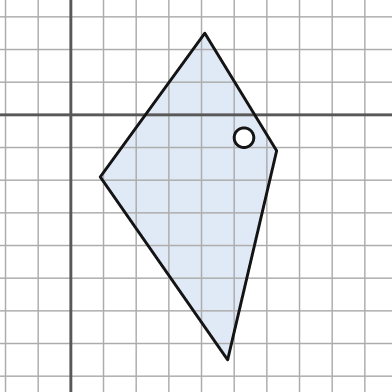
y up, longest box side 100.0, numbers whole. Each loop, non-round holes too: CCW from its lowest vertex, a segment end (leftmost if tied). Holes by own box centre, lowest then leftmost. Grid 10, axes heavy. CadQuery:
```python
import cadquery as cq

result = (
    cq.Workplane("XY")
    .moveTo(48.0, -75.0)
    .lineTo(63.0, -11.0)
    .lineTo(41.0, 25.0)
    .lineTo(9.0, -19.0)
    .close()
    .moveTo(53.0, -7.0)
    .circle(3.0)
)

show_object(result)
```